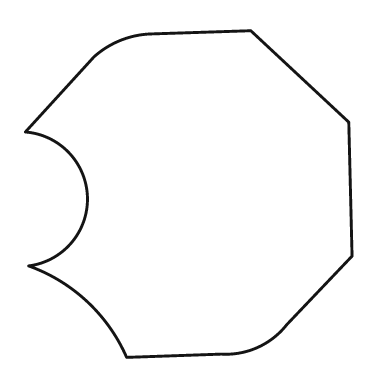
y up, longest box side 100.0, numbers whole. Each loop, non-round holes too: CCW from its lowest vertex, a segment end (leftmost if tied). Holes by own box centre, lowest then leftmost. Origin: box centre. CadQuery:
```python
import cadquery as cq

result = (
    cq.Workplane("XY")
    .moveTo(-19.0, -50.0)
    .lineTo(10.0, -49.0)
    .threePointArc((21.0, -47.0), (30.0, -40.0))
    .lineTo(50.0, -19.0)
    .lineTo(49.0, 22.0)
    .lineTo(19.0, 50.0)
    .lineTo(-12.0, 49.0)
    .threePointArc((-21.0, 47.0), (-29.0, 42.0))
    .lineTo(-50.0, 19.0)
    .threePointArc((-31.0, -1.0), (-49.0, -22.0))
    .threePointArc((-31.0, -33.0), (-19.0, -50.0))
    .close()
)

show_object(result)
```